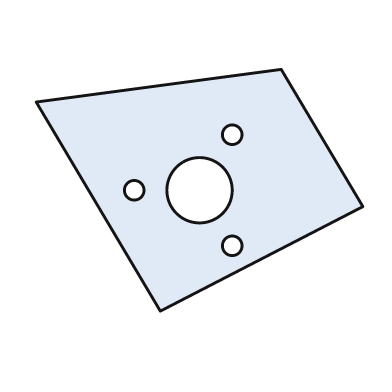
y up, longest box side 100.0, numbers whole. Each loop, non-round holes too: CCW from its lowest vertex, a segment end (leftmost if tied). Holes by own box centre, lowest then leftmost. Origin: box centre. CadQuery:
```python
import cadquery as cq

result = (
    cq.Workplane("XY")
    .moveTo(-12.0, -37.0)
    .lineTo(50.0, -5.0)
    .lineTo(25.0, 37.0)
    .lineTo(-50.0, 27.0)
    .close()
    .moveTo(10.0, -17.0)
    .circle(3.0)
    .moveTo(-20.0, 0.0)
    .circle(3.0)
    .moveTo(0.0, 0.0)
    .circle(10.0)
    .moveTo(10.0, 17.0)
    .circle(3.0)
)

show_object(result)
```